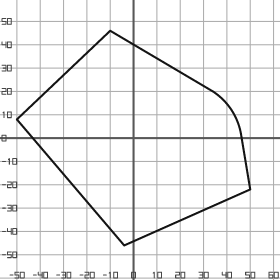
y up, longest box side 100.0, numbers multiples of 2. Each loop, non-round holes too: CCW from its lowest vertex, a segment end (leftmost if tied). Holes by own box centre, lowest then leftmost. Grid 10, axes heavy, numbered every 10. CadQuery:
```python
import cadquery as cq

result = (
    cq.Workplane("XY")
    .moveTo(-4.0, -46.0)
    .lineTo(50.0, -22.0)
    .lineTo(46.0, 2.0)
    .threePointArc((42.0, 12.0), (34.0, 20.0))
    .lineTo(-10.0, 46.0)
    .lineTo(-50.0, 8.0)
    .close()
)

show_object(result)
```